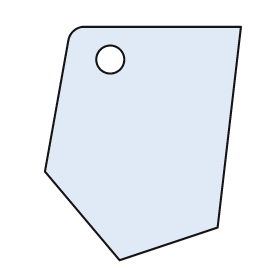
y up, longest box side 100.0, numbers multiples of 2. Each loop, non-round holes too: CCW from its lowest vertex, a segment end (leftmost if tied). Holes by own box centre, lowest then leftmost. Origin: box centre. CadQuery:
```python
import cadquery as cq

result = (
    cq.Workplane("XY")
    .moveTo(-10.0, -50.0)
    .lineTo(32.0, -36.0)
    .lineTo(42.0, 50.0)
    .lineTo(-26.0, 50.0)
    .threePointArc((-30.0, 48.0), (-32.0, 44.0))
    .lineTo(-42.0, -12.0)
    .close()
    .moveTo(-14.0, 36.0)
    .circle(6.0)
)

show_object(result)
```